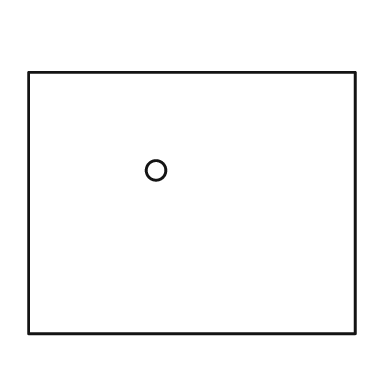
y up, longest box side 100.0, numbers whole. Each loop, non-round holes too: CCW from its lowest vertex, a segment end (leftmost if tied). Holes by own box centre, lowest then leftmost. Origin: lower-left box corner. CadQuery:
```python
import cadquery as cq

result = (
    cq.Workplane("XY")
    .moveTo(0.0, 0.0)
    .lineTo(100.0, 0.0)
    .lineTo(100.0, 80.0)
    .lineTo(0.0, 80.0)
    .close()
    .moveTo(39.0, 50.0)
    .circle(3.0)
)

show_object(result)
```